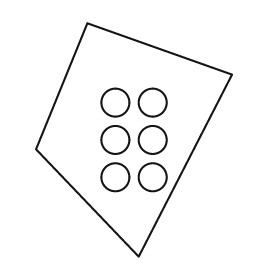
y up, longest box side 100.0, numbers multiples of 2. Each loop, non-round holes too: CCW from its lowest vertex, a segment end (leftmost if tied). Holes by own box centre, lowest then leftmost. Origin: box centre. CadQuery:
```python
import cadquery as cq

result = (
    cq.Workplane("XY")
    .moveTo(2.0, -50.0)
    .lineTo(42.0, 28.0)
    .lineTo(-20.0, 50.0)
    .lineTo(-42.0, -4.0)
    .close()
    .moveTo(-8.0, -16.0)
    .circle(6.0)
    .moveTo(8.0, -16.0)
    .circle(6.0)
    .moveTo(-8.0, 0.0)
    .circle(6.0)
    .moveTo(8.0, 0.0)
    .circle(6.0)
    .moveTo(-8.0, 16.0)
    .circle(6.0)
    .moveTo(8.0, 16.0)
    .circle(6.0)
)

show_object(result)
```